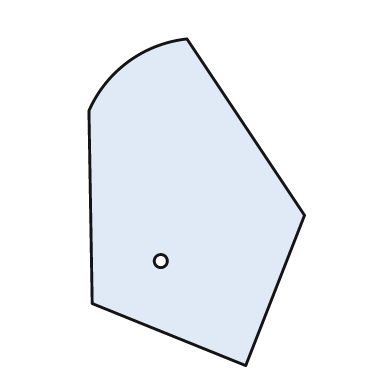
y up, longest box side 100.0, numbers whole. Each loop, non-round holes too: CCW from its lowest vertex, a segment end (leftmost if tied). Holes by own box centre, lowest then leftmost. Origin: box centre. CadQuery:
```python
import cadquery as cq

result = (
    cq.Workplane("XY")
    .moveTo(15.0, -50.0)
    .lineTo(33.0, -4.0)
    .lineTo(-3.0, 50.0)
    .threePointArc((-21.0, 43.0), (-33.0, 28.0))
    .lineTo(-32.0, -31.0)
    .close()
    .moveTo(-11.0, -18.0)
    .circle(2.0)
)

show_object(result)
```